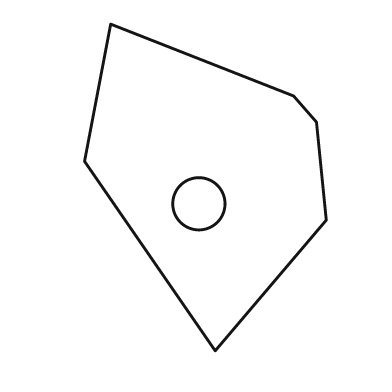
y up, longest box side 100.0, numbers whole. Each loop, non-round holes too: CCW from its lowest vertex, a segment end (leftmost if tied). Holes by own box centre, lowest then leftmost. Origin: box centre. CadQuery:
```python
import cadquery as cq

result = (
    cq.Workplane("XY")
    .moveTo(3.0, -50.0)
    .lineTo(37.0, -10.0)
    .lineTo(34.0, 20.0)
    .lineTo(27.0, 28.0)
    .lineTo(-29.0, 50.0)
    .lineTo(-37.0, 8.0)
    .close()
    .moveTo(-2.0, -5.0)
    .circle(8.0)
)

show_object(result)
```